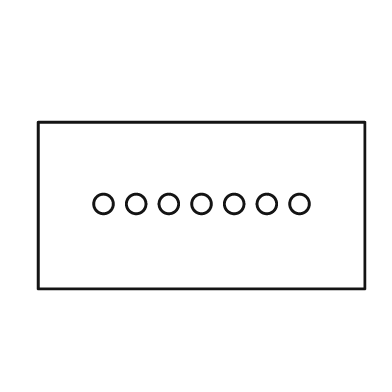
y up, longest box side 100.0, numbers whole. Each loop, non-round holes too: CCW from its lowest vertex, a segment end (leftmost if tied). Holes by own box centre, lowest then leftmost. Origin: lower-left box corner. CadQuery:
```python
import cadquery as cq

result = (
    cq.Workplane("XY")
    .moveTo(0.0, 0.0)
    .lineTo(100.0, 0.0)
    .lineTo(100.0, 51.0)
    .lineTo(0.0, 51.0)
    .close()
    .moveTo(20.0, 26.0)
    .circle(3.0)
    .moveTo(30.0, 26.0)
    .circle(3.0)
    .moveTo(40.0, 26.0)
    .circle(3.0)
    .moveTo(50.0, 26.0)
    .circle(3.0)
    .moveTo(60.0, 26.0)
    .circle(3.0)
    .moveTo(70.0, 26.0)
    .circle(3.0)
    .moveTo(80.0, 26.0)
    .circle(3.0)
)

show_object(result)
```